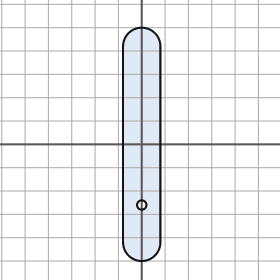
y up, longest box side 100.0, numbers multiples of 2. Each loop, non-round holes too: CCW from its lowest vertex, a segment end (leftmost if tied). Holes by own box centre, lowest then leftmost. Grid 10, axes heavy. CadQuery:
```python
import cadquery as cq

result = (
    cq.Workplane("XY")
    .moveTo(-8.0, -42.0)
    .threePointArc((0.0, -50.0), (8.0, -42.0))
    .lineTo(8.0, 42.0)
    .threePointArc((0.0, 50.0), (-8.0, 42.0))
    .close()
    .moveTo(0.0, -26.0)
    .circle(2.0)
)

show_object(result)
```